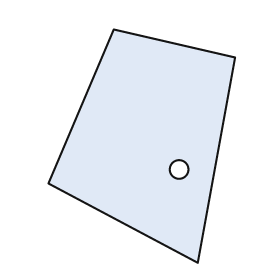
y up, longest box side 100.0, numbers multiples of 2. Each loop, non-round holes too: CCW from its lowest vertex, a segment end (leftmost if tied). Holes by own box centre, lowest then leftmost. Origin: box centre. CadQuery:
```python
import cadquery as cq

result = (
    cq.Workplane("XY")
    .moveTo(24.0, -50.0)
    .lineTo(40.0, 38.0)
    .lineTo(-12.0, 50.0)
    .lineTo(-40.0, -16.0)
    .close()
    .moveTo(16.0, -10.0)
    .circle(4.0)
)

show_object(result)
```